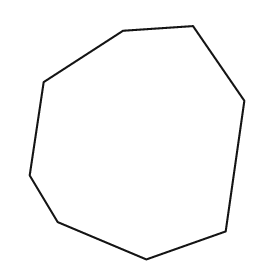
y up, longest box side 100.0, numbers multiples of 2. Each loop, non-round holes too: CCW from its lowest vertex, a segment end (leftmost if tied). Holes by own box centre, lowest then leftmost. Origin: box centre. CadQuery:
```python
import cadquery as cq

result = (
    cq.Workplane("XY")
    .moveTo(4.0, -50.0)
    .lineTo(38.0, -38.0)
    .lineTo(46.0, 18.0)
    .lineTo(24.0, 50.0)
    .lineTo(-6.0, 48.0)
    .lineTo(-40.0, 26.0)
    .lineTo(-46.0, -14.0)
    .lineTo(-34.0, -34.0)
    .close()
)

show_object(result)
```